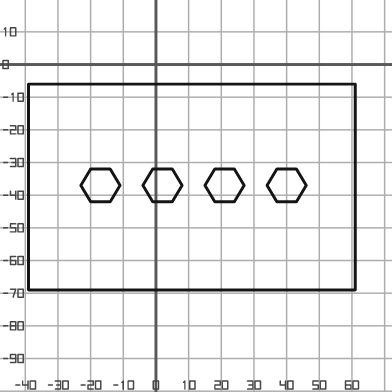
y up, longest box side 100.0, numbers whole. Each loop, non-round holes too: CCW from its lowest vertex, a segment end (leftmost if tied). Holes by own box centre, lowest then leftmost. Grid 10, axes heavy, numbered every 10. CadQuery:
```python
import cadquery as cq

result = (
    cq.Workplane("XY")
    .moveTo(-39.0, -69.0)
    .lineTo(61.0, -69.0)
    .lineTo(61.0, -6.0)
    .lineTo(-39.0, -6.0)
    .close()
    .moveTo(-20.0, -42.0)
    .lineTo(-14.0, -42.0)
    .lineTo(-11.0, -37.0)
    .lineTo(-14.0, -32.0)
    .lineTo(-20.0, -32.0)
    .lineTo(-23.0, -37.0)
    .close()
    .moveTo(-1.0, -42.0)
    .lineTo(5.0, -42.0)
    .lineTo(8.0, -37.0)
    .lineTo(5.0, -32.0)
    .lineTo(-1.0, -32.0)
    .lineTo(-4.0, -37.0)
    .close()
    .moveTo(18.0, -42.0)
    .lineTo(24.0, -42.0)
    .lineTo(27.0, -37.0)
    .lineTo(24.0, -32.0)
    .lineTo(18.0, -32.0)
    .lineTo(15.0, -37.0)
    .close()
    .moveTo(37.0, -42.0)
    .lineTo(43.0, -42.0)
    .lineTo(46.0, -37.0)
    .lineTo(43.0, -32.0)
    .lineTo(37.0, -32.0)
    .lineTo(34.0, -37.0)
    .close()
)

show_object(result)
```